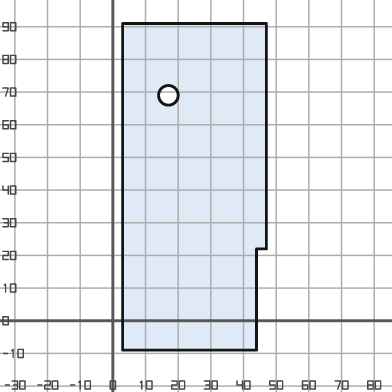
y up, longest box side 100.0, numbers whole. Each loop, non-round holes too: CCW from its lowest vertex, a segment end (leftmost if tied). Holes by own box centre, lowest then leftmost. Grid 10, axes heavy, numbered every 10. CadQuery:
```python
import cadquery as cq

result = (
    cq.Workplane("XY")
    .moveTo(3.0, -9.0)
    .lineTo(44.0, -9.0)
    .lineTo(44.0, 22.0)
    .lineTo(47.0, 22.0)
    .lineTo(47.0, 91.0)
    .lineTo(3.0, 91.0)
    .close()
    .moveTo(17.0, 69.0)
    .circle(3.0)
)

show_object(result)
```